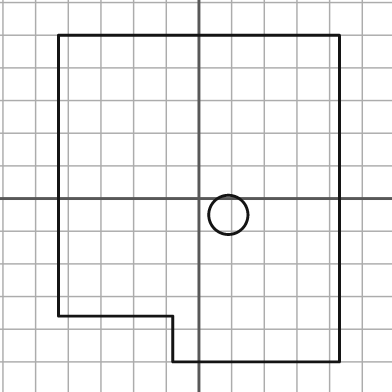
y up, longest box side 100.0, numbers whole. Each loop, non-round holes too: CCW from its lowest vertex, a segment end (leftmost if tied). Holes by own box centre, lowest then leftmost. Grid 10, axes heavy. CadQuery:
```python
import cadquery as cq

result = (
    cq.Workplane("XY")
    .moveTo(-8.0, -50.0)
    .lineTo(43.0, -50.0)
    .lineTo(43.0, 50.0)
    .lineTo(-43.0, 50.0)
    .lineTo(-43.0, -36.0)
    .lineTo(-8.0, -36.0)
    .close()
    .moveTo(9.0, -5.0)
    .circle(6.0)
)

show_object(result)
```